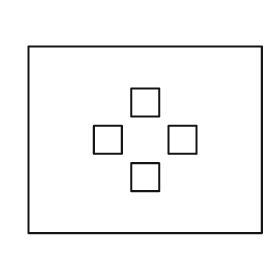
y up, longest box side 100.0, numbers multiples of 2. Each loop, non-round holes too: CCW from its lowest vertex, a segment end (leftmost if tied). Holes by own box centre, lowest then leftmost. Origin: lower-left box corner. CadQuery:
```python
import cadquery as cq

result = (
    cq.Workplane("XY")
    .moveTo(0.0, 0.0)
    .lineTo(100.0, 0.0)
    .lineTo(100.0, 80.0)
    .lineTo(0.0, 80.0)
    .close()
    .moveTo(44.0, 18.0)
    .lineTo(56.0, 18.0)
    .lineTo(56.0, 30.0)
    .lineTo(44.0, 30.0)
    .close()
    .moveTo(28.0, 34.0)
    .lineTo(40.0, 34.0)
    .lineTo(40.0, 46.0)
    .lineTo(28.0, 46.0)
    .close()
    .moveTo(60.0, 34.0)
    .lineTo(72.0, 34.0)
    .lineTo(72.0, 46.0)
    .lineTo(60.0, 46.0)
    .close()
    .moveTo(44.0, 50.0)
    .lineTo(56.0, 50.0)
    .lineTo(56.0, 62.0)
    .lineTo(44.0, 62.0)
    .close()
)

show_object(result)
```